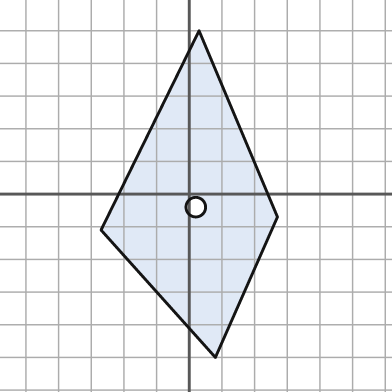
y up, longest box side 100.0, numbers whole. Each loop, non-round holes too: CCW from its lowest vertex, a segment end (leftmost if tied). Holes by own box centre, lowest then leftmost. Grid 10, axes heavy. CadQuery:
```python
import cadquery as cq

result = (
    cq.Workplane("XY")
    .moveTo(8.0, -50.0)
    .lineTo(27.0, -7.0)
    .lineTo(3.0, 50.0)
    .lineTo(-27.0, -11.0)
    .close()
    .moveTo(2.0, -4.0)
    .circle(3.0)
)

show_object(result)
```